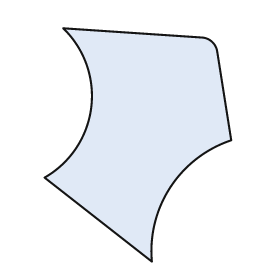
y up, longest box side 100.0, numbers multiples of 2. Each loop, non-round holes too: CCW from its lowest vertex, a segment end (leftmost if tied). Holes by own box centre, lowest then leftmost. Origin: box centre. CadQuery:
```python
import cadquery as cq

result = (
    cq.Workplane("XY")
    .moveTo(6.0, -50.0)
    .threePointArc((14.0, -18.0), (40.0, 2.0))
    .lineTo(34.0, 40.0)
    .threePointArc((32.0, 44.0), (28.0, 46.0))
    .lineTo(-32.0, 50.0)
    .threePointArc((-20.0, 16.0), (-40.0, -14.0))
    .close()
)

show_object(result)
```